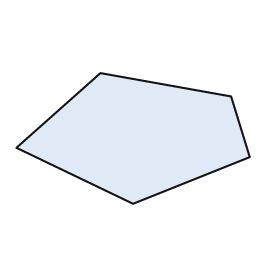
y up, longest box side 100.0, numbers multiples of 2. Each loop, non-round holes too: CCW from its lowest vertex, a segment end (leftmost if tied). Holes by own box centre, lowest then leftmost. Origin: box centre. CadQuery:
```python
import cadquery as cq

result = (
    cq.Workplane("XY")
    .moveTo(0.0, -28.0)
    .lineTo(50.0, -8.0)
    .lineTo(42.0, 18.0)
    .lineTo(-14.0, 28.0)
    .lineTo(-50.0, -4.0)
    .close()
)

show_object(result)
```